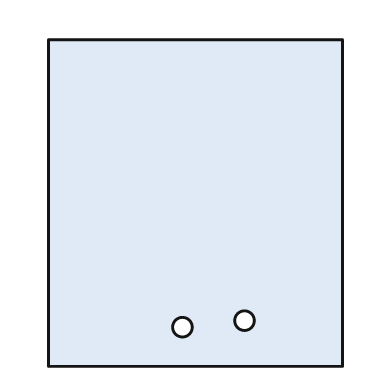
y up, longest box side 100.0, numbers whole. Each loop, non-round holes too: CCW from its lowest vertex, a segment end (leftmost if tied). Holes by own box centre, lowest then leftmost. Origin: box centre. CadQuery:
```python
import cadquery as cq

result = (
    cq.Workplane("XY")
    .moveTo(-45.0, -50.0)
    .lineTo(45.0, -50.0)
    .lineTo(45.0, 50.0)
    .lineTo(-45.0, 50.0)
    .close()
    .moveTo(-4.0, -38.0)
    .circle(3.0)
    .moveTo(15.0, -36.0)
    .circle(3.0)
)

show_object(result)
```